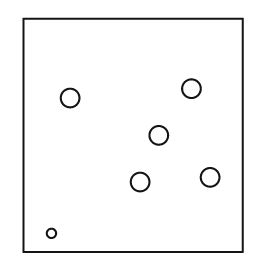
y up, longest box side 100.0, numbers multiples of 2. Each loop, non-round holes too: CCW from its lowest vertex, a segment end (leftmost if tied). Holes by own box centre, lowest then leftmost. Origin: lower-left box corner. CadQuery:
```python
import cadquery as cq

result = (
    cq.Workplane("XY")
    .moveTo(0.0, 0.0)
    .lineTo(94.0, 0.0)
    .lineTo(94.0, 100.0)
    .lineTo(0.0, 100.0)
    .close()
    .moveTo(12.0, 8.0)
    .circle(2.0)
    .moveTo(50.0, 30.0)
    .circle(4.0)
    .moveTo(80.0, 32.0)
    .circle(4.0)
    .moveTo(58.0, 50.0)
    .circle(4.0)
    .moveTo(20.0, 66.0)
    .circle(4.0)
    .moveTo(72.0, 70.0)
    .circle(4.0)
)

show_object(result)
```